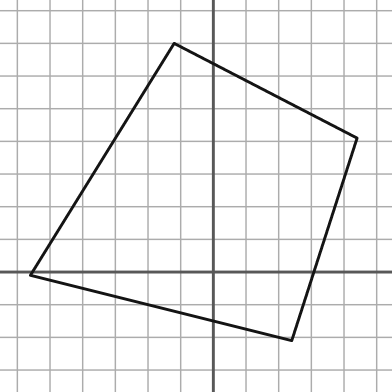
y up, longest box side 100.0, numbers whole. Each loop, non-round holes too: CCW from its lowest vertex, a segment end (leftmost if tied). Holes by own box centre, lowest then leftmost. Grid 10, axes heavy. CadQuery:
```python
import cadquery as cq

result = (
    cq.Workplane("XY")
    .moveTo(24.0, -21.0)
    .lineTo(44.0, 41.0)
    .lineTo(-12.0, 70.0)
    .lineTo(-56.0, -1.0)
    .close()
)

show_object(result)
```